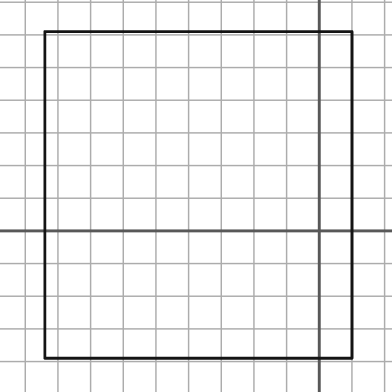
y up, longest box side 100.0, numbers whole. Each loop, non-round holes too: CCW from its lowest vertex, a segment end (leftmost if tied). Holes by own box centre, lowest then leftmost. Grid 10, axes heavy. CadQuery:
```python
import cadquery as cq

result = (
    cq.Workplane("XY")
    .moveTo(-84.0, -39.0)
    .lineTo(10.0, -39.0)
    .lineTo(10.0, 61.0)
    .lineTo(-84.0, 61.0)
    .close()
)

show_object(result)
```